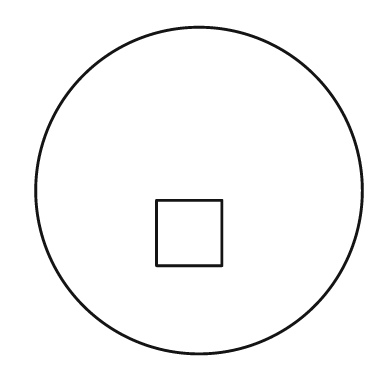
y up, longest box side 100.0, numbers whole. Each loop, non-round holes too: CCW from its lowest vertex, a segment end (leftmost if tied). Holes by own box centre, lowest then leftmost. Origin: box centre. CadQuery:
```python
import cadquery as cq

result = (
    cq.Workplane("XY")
    .moveTo(0.0, 0.0)
    .circle(50.0)
    .moveTo(-13.0, -23.0)
    .lineTo(7.0, -23.0)
    .lineTo(7.0, -3.0)
    .lineTo(-13.0, -3.0)
    .close()
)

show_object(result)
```